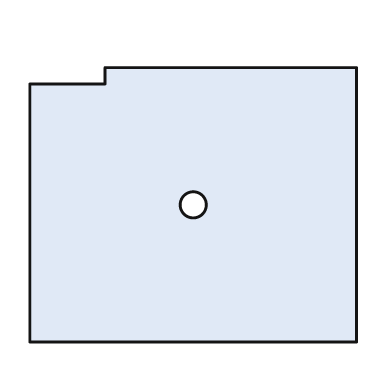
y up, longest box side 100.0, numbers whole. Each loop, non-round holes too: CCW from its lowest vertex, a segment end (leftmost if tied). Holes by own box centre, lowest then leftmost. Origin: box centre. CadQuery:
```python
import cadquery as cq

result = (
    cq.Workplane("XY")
    .moveTo(-50.0, -42.0)
    .lineTo(50.0, -42.0)
    .lineTo(50.0, 42.0)
    .lineTo(-27.0, 42.0)
    .lineTo(-27.0, 37.0)
    .lineTo(-50.0, 37.0)
    .close()
    .moveTo(0.0, 0.0)
    .circle(4.0)
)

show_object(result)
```